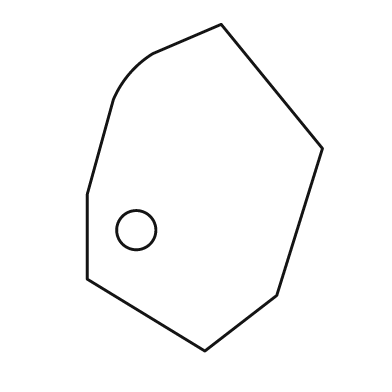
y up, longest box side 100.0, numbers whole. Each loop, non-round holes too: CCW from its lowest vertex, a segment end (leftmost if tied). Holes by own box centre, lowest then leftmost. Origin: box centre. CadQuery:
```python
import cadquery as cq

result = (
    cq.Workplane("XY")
    .moveTo(0.0, -50.0)
    .lineTo(22.0, -33.0)
    .lineTo(36.0, 12.0)
    .lineTo(5.0, 50.0)
    .lineTo(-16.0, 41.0)
    .threePointArc((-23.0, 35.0), (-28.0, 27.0))
    .lineTo(-36.0, -2.0)
    .lineTo(-36.0, -28.0)
    .close()
    .moveTo(-21.0, -13.0)
    .circle(6.0)
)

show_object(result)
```